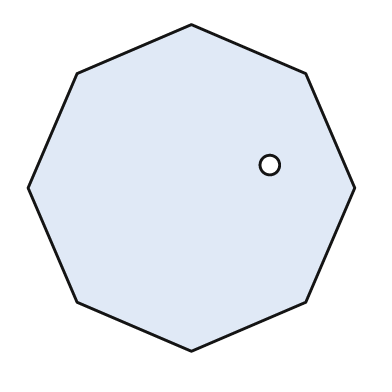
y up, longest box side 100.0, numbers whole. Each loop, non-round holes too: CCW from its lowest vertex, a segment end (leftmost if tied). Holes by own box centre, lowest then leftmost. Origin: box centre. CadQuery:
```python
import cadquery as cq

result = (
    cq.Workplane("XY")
    .moveTo(0.0, -50.0)
    .lineTo(35.0, -35.0)
    .lineTo(50.0, 0.0)
    .lineTo(35.0, 35.0)
    .lineTo(0.0, 50.0)
    .lineTo(-35.0, 35.0)
    .lineTo(-50.0, 0.0)
    .lineTo(-35.0, -35.0)
    .close()
    .moveTo(24.0, 7.0)
    .circle(3.0)
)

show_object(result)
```